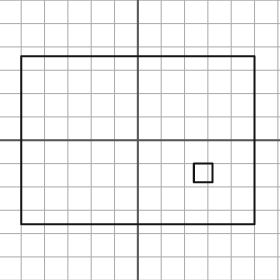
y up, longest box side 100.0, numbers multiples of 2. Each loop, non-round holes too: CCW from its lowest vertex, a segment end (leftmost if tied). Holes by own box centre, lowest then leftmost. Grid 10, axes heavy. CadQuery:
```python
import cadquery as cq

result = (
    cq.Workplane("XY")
    .moveTo(-50.0, -36.0)
    .lineTo(50.0, -36.0)
    .lineTo(50.0, 36.0)
    .lineTo(-50.0, 36.0)
    .close()
    .moveTo(24.0, -18.0)
    .lineTo(32.0, -18.0)
    .lineTo(32.0, -10.0)
    .lineTo(24.0, -10.0)
    .close()
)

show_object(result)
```